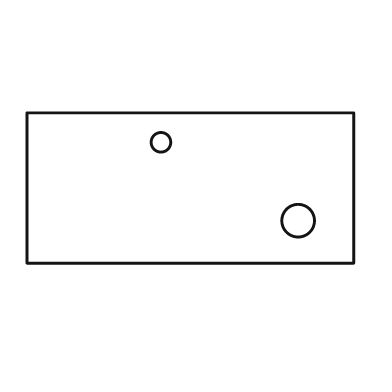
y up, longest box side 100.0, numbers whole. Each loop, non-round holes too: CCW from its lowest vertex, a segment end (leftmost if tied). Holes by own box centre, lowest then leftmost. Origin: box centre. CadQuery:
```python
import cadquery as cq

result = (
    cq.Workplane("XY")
    .moveTo(-50.0, -23.0)
    .lineTo(50.0, -23.0)
    .lineTo(50.0, 23.0)
    .lineTo(-50.0, 23.0)
    .close()
    .moveTo(33.0, -10.0)
    .circle(5.0)
    .moveTo(-9.0, 14.0)
    .circle(3.0)
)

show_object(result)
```